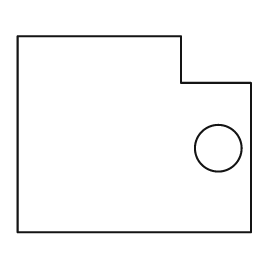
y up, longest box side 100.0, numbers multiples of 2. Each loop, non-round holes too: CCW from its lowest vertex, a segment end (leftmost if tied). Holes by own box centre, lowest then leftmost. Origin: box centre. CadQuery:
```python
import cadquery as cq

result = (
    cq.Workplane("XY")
    .moveTo(-50.0, -42.0)
    .lineTo(50.0, -42.0)
    .lineTo(50.0, 22.0)
    .lineTo(20.0, 22.0)
    .lineTo(20.0, 42.0)
    .lineTo(-50.0, 42.0)
    .close()
    .moveTo(36.0, -6.0)
    .circle(10.0)
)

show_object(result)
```